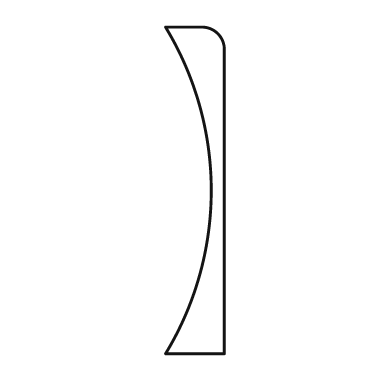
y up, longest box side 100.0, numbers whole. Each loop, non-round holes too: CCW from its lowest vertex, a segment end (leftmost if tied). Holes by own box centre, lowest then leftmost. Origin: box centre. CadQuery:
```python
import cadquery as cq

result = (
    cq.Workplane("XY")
    .moveTo(-9.0, -50.0)
    .lineTo(9.0, -50.0)
    .lineTo(9.0, 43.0)
    .threePointArc((7.0, 48.0), (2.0, 50.0))
    .lineTo(-9.0, 50.0)
    .threePointArc((5.0, 0.0), (-9.0, -50.0))
    .close()
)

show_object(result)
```